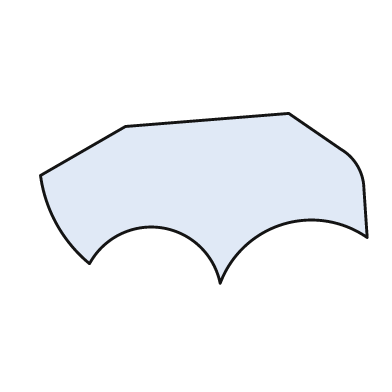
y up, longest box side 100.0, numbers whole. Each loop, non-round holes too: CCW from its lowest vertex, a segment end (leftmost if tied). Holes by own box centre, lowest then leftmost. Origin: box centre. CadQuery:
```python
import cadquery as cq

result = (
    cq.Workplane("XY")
    .moveTo(5.0, -26.0)
    .threePointArc((24.0, -8.0), (50.0, -12.0))
    .lineTo(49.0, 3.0)
    .threePointArc((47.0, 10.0), (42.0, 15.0))
    .lineTo(26.0, 26.0)
    .lineTo(-24.0, 22.0)
    .lineTo(-50.0, 7.0)
    .threePointArc((-45.0, -8.0), (-35.0, -20.0))
    .threePointArc((-13.0, -9.0), (5.0, -26.0))
    .close()
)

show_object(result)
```